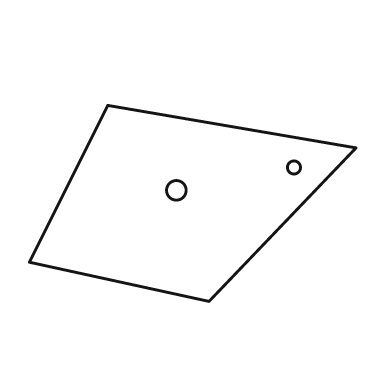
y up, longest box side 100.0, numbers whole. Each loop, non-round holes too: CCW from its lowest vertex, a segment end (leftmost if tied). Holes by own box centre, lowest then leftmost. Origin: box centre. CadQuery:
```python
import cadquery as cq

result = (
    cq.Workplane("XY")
    .moveTo(5.0, -30.0)
    .lineTo(50.0, 17.0)
    .lineTo(-26.0, 30.0)
    .lineTo(-50.0, -18.0)
    .close()
    .moveTo(-5.0, 4.0)
    .circle(3.0)
    .moveTo(31.0, 11.0)
    .circle(2.0)
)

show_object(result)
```